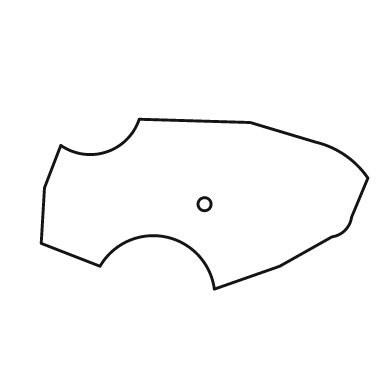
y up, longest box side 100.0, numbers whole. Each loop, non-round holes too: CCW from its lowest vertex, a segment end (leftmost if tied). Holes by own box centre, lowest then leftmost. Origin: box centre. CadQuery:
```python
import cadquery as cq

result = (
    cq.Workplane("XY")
    .moveTo(3.0, -26.0)
    .lineTo(23.0, -19.0)
    .lineTo(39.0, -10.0)
    .threePointArc((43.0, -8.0), (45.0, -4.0))
    .lineTo(50.0, 8.0)
    .threePointArc((43.0, 15.0), (34.0, 19.0))
    .lineTo(14.0, 25.0)
    .lineTo(-20.0, 26.0)
    .threePointArc((-30.0, 16.0), (-44.0, 18.0))
    .lineTo(-49.0, 5.0)
    .lineTo(-50.0, -12.0)
    .lineTo(-32.0, -19.0)
    .threePointArc((-12.0, -10.0), (3.0, -26.0))
    .close()
    .moveTo(0.0, 0.0)
    .circle(2.0)
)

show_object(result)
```